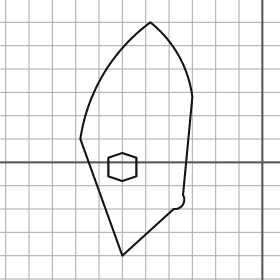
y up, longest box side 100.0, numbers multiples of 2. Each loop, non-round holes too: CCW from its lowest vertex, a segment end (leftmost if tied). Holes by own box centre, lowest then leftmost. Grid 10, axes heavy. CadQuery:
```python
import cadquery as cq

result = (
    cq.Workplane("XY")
    .moveTo(-60.0, -40.0)
    .lineTo(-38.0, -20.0)
    .threePointArc((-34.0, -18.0), (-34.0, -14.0))
    .lineTo(-30.0, 28.0)
    .threePointArc((-36.0, 46.0), (-48.0, 60.0))
    .threePointArc((-68.0, 38.0), (-78.0, 10.0))
    .close()
    .moveTo(-60.0, -8.0)
    .lineTo(-54.0, -6.0)
    .lineTo(-54.0, 2.0)
    .lineTo(-60.0, 4.0)
    .lineTo(-66.0, 2.0)
    .lineTo(-66.0, -6.0)
    .close()
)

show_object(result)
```